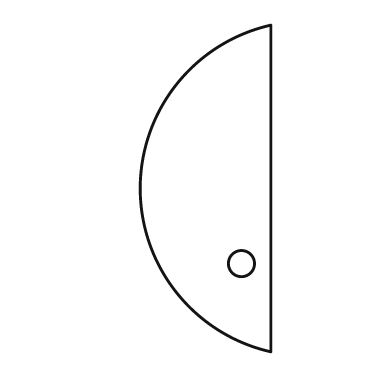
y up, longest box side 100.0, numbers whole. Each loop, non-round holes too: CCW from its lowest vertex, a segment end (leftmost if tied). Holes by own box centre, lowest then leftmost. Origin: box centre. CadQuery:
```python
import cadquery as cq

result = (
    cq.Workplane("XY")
    .moveTo(20.0, -50.0)
    .lineTo(20.0, 50.0)
    .threePointArc((-20.0, 0.0), (20.0, -50.0))
    .close()
    .moveTo(11.0, -23.0)
    .circle(4.0)
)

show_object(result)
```